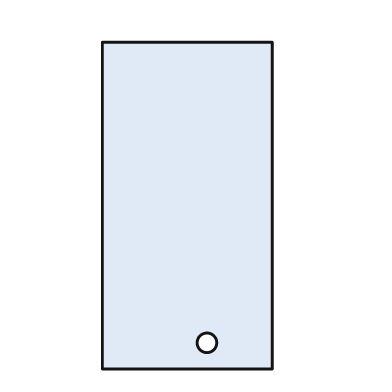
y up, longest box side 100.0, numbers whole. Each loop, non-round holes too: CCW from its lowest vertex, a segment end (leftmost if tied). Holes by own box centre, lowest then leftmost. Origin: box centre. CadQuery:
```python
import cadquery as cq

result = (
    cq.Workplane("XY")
    .moveTo(-26.0, -50.0)
    .lineTo(26.0, -50.0)
    .lineTo(26.0, 50.0)
    .lineTo(-26.0, 50.0)
    .close()
    .moveTo(6.0, -42.0)
    .circle(3.0)
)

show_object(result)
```